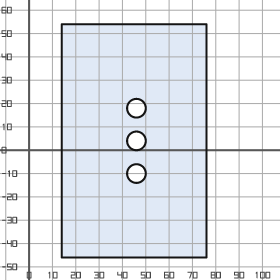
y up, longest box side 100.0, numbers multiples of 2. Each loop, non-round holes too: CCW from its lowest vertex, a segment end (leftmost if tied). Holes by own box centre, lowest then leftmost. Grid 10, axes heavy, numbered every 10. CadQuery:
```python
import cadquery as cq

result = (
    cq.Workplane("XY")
    .moveTo(14.0, -46.0)
    .lineTo(76.0, -46.0)
    .lineTo(76.0, 54.0)
    .lineTo(14.0, 54.0)
    .close()
    .moveTo(46.0, -10.0)
    .circle(4.0)
    .moveTo(46.0, 4.0)
    .circle(4.0)
    .moveTo(46.0, 18.0)
    .circle(4.0)
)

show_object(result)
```